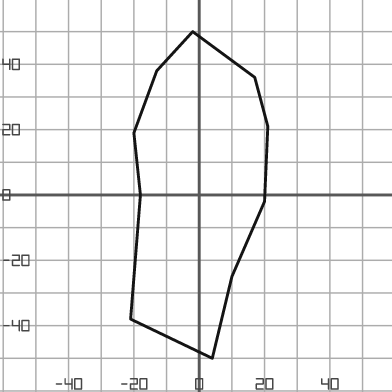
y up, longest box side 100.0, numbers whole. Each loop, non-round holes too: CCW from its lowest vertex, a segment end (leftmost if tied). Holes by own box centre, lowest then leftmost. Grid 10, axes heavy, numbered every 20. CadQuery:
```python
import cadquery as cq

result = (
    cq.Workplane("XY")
    .moveTo(4.0, -50.0)
    .lineTo(10.0, -25.0)
    .lineTo(20.0, -2.0)
    .lineTo(21.0, 21.0)
    .lineTo(17.0, 36.0)
    .lineTo(-2.0, 50.0)
    .lineTo(-13.0, 38.0)
    .lineTo(-20.0, 19.0)
    .lineTo(-18.0, 0.0)
    .lineTo(-21.0, -38.0)
    .close()
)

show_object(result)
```